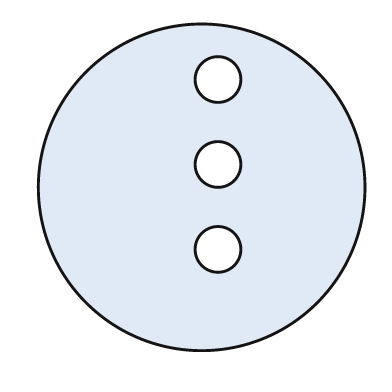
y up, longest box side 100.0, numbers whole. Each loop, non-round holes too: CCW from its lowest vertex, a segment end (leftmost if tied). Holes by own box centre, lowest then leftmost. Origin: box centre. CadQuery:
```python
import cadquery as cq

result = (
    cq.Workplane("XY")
    .moveTo(0.0, 0.0)
    .circle(50.0)
    .moveTo(5.0, -19.0)
    .circle(7.0)
    .moveTo(5.0, 7.0)
    .circle(7.0)
    .moveTo(5.0, 33.0)
    .circle(7.0)
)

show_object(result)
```